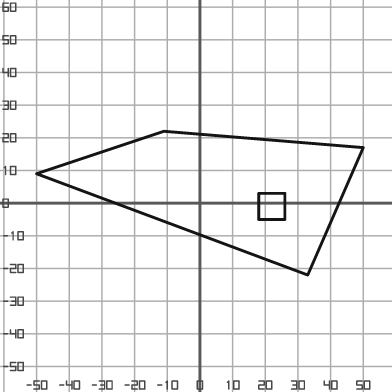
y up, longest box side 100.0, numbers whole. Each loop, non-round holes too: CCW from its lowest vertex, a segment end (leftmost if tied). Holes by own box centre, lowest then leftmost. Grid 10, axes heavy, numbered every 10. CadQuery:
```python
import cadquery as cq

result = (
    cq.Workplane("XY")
    .moveTo(33.0, -22.0)
    .lineTo(50.0, 17.0)
    .lineTo(-11.0, 22.0)
    .lineTo(-50.0, 9.0)
    .close()
    .moveTo(18.0, -5.0)
    .lineTo(26.0, -5.0)
    .lineTo(26.0, 3.0)
    .lineTo(18.0, 3.0)
    .close()
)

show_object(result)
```